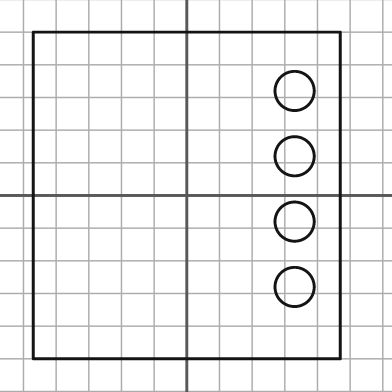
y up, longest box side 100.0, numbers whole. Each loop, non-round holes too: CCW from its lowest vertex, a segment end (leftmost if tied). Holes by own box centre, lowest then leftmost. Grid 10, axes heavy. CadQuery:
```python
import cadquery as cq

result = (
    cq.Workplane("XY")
    .moveTo(-47.0, -50.0)
    .lineTo(47.0, -50.0)
    .lineTo(47.0, 50.0)
    .lineTo(-47.0, 50.0)
    .close()
    .moveTo(33.0, -28.0)
    .circle(6.0)
    .moveTo(33.0, -8.0)
    .circle(6.0)
    .moveTo(33.0, 12.0)
    .circle(6.0)
    .moveTo(33.0, 32.0)
    .circle(6.0)
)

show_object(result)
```